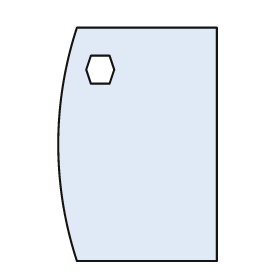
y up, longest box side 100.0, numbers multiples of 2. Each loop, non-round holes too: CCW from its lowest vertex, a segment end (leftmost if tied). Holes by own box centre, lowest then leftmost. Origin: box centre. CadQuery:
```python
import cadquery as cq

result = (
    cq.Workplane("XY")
    .moveTo(-26.0, -50.0)
    .lineTo(34.0, -50.0)
    .lineTo(34.0, 50.0)
    .lineTo(-26.0, 50.0)
    .threePointArc((-34.0, 0.0), (-26.0, -50.0))
    .close()
    .moveTo(-20.0, 26.0)
    .lineTo(-12.0, 26.0)
    .lineTo(-10.0, 32.0)
    .lineTo(-12.0, 38.0)
    .lineTo(-20.0, 38.0)
    .lineTo(-22.0, 32.0)
    .close()
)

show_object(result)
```